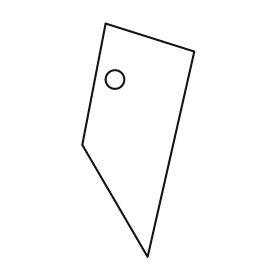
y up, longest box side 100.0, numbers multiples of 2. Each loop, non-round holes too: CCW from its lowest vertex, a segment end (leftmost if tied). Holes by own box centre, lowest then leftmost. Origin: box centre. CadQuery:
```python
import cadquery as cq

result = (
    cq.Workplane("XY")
    .moveTo(4.0, -50.0)
    .lineTo(24.0, 38.0)
    .lineTo(-14.0, 50.0)
    .lineTo(-24.0, -2.0)
    .close()
    .moveTo(-10.0, 26.0)
    .circle(4.0)
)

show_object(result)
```